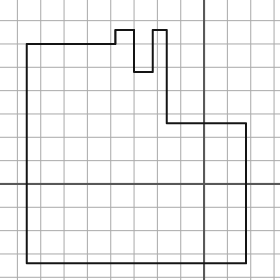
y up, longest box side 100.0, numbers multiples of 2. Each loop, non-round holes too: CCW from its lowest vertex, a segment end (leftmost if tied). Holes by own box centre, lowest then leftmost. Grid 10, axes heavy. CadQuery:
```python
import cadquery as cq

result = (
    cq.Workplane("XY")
    .moveTo(-76.0, -34.0)
    .lineTo(18.0, -34.0)
    .lineTo(18.0, 26.0)
    .lineTo(-16.0, 26.0)
    .lineTo(-16.0, 66.0)
    .lineTo(-22.0, 66.0)
    .lineTo(-22.0, 48.0)
    .lineTo(-30.0, 48.0)
    .lineTo(-30.0, 66.0)
    .lineTo(-38.0, 66.0)
    .lineTo(-38.0, 60.0)
    .lineTo(-76.0, 60.0)
    .close()
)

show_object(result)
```